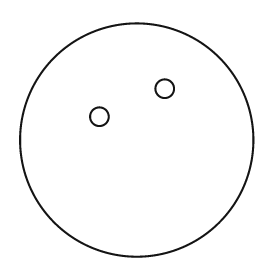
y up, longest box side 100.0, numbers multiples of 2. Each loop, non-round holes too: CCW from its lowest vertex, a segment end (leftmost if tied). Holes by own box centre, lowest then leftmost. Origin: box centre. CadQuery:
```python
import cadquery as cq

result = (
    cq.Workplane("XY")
    .moveTo(0.0, 0.0)
    .circle(50.0)
    .moveTo(-16.0, 10.0)
    .circle(4.0)
    .moveTo(12.0, 22.0)
    .circle(4.0)
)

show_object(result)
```